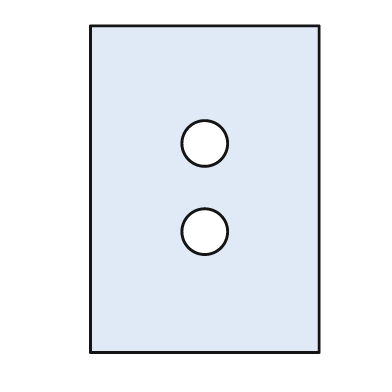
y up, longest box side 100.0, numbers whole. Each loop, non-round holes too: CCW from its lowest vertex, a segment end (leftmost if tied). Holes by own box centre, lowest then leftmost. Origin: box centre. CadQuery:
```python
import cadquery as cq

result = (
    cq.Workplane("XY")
    .moveTo(-35.0, -50.0)
    .lineTo(35.0, -50.0)
    .lineTo(35.0, 50.0)
    .lineTo(-35.0, 50.0)
    .close()
    .moveTo(0.0, -13.0)
    .circle(7.0)
    .moveTo(0.0, 14.0)
    .circle(7.0)
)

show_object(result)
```